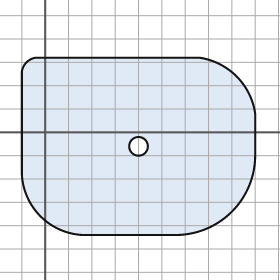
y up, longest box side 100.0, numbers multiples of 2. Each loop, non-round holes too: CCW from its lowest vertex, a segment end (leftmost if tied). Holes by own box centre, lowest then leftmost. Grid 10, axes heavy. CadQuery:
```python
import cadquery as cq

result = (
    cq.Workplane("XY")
    .moveTo(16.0, -44.0)
    .lineTo(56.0, -44.0)
    .threePointArc((80.0, -34.0), (90.0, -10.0))
    .lineTo(90.0, 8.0)
    .threePointArc((82.0, 24.0), (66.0, 32.0))
    .lineTo(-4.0, 32.0)
    .threePointArc((-8.0, 30.0), (-10.0, 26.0))
    .lineTo(-10.0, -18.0)
    .threePointArc((-2.0, -36.0), (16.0, -44.0))
    .close()
    .moveTo(40.0, -6.0)
    .circle(4.0)
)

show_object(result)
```